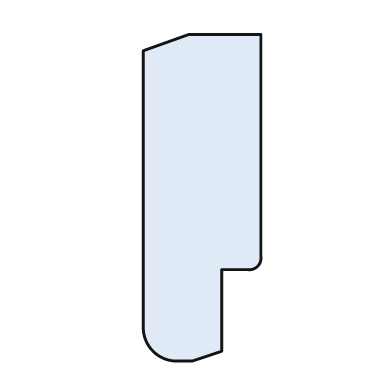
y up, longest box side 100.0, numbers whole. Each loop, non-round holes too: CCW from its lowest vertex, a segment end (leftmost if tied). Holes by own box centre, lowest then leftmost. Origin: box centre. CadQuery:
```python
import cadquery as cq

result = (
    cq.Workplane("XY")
    .moveTo(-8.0, -50.0)
    .lineTo(-3.0, -50.0)
    .lineTo(6.0, -47.0)
    .lineTo(6.0, -22.0)
    .lineTo(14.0, -22.0)
    .threePointArc((17.0, -21.0), (18.0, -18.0))
    .lineTo(18.0, 50.0)
    .lineTo(-4.0, 50.0)
    .lineTo(-18.0, 45.0)
    .lineTo(-18.0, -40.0)
    .threePointArc((-15.0, -47.0), (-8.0, -50.0))
    .close()
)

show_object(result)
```